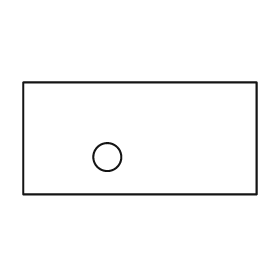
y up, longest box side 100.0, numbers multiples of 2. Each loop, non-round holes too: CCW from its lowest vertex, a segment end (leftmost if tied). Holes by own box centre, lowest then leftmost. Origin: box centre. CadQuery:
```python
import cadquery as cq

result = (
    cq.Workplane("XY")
    .moveTo(-50.0, -24.0)
    .lineTo(50.0, -24.0)
    .lineTo(50.0, 24.0)
    .lineTo(-50.0, 24.0)
    .close()
    .moveTo(-14.0, -8.0)
    .circle(6.0)
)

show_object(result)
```